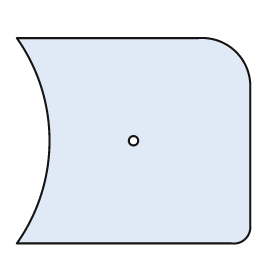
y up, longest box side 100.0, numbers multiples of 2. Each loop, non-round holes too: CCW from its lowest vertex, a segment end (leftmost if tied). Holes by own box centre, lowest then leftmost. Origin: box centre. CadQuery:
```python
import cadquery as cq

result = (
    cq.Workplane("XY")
    .moveTo(-50.0, -44.0)
    .lineTo(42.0, -44.0)
    .threePointArc((48.0, -42.0), (50.0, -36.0))
    .lineTo(50.0, 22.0)
    .threePointArc((44.0, 38.0), (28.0, 44.0))
    .lineTo(-50.0, 44.0)
    .threePointArc((-36.0, 0.0), (-50.0, -44.0))
    .close()
    .moveTo(0.0, 0.0)
    .circle(2.0)
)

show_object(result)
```